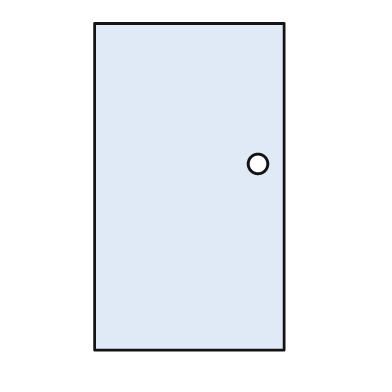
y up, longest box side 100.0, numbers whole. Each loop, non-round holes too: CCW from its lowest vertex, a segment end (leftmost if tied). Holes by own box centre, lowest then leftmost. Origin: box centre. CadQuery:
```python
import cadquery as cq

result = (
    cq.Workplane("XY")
    .moveTo(-29.0, -50.0)
    .lineTo(29.0, -50.0)
    .lineTo(29.0, 50.0)
    .lineTo(-29.0, 50.0)
    .close()
    .moveTo(21.0, 7.0)
    .circle(3.0)
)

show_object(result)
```